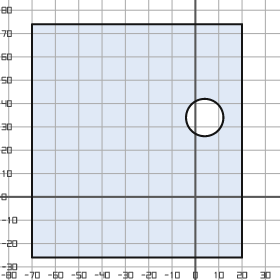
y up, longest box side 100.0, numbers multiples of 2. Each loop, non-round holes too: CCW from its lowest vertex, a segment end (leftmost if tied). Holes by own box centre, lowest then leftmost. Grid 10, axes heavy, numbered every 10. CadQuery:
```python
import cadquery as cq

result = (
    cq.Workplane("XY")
    .moveTo(-70.0, -26.0)
    .lineTo(20.0, -26.0)
    .lineTo(20.0, 74.0)
    .lineTo(-70.0, 74.0)
    .close()
    .moveTo(4.0, 34.0)
    .circle(8.0)
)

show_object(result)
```